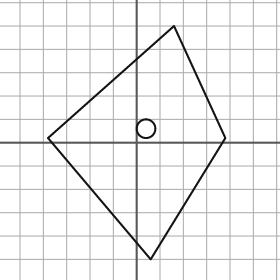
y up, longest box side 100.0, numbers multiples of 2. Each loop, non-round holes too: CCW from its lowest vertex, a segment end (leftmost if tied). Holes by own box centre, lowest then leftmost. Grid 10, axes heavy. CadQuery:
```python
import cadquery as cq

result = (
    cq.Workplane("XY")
    .moveTo(6.0, -50.0)
    .lineTo(38.0, 2.0)
    .lineTo(16.0, 50.0)
    .lineTo(-38.0, 2.0)
    .close()
    .moveTo(4.0, 6.0)
    .circle(4.0)
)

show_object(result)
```